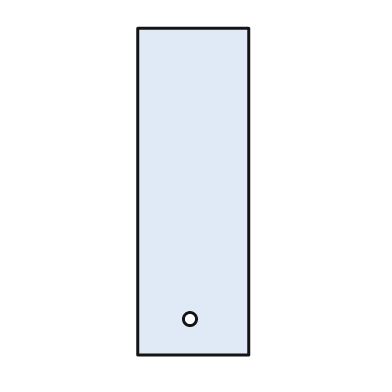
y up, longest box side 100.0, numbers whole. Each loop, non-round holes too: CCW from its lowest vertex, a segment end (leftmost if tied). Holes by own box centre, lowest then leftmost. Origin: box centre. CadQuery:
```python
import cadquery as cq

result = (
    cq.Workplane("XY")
    .moveTo(-17.0, -50.0)
    .lineTo(17.0, -50.0)
    .lineTo(17.0, 50.0)
    .lineTo(-17.0, 50.0)
    .close()
    .moveTo(-1.0, -39.0)
    .circle(2.0)
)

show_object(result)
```